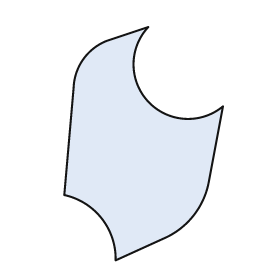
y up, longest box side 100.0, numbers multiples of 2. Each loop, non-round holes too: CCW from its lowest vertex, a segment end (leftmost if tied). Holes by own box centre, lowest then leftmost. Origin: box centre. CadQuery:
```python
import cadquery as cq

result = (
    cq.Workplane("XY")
    .moveTo(-12.0, -50.0)
    .lineTo(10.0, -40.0)
    .threePointArc((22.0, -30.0), (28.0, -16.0))
    .lineTo(34.0, 16.0)
    .threePointArc((2.0, 18.0), (2.0, 50.0))
    .lineTo(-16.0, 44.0)
    .threePointArc((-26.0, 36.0), (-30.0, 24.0))
    .lineTo(-34.0, -22.0)
    .threePointArc((-18.0, -32.0), (-12.0, -50.0))
    .close()
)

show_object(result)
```